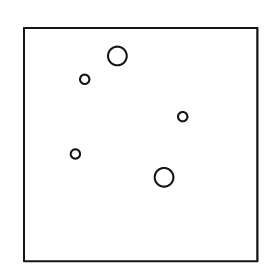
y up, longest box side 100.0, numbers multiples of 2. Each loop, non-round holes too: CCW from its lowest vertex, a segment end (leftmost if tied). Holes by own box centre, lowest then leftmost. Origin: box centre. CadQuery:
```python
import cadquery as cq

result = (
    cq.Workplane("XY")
    .moveTo(-50.0, -50.0)
    .lineTo(50.0, -50.0)
    .lineTo(50.0, 50.0)
    .lineTo(-50.0, 50.0)
    .close()
    .moveTo(10.0, -14.0)
    .circle(4.0)
    .moveTo(-28.0, -4.0)
    .circle(2.0)
    .moveTo(18.0, 12.0)
    .circle(2.0)
    .moveTo(-24.0, 28.0)
    .circle(2.0)
    .moveTo(-10.0, 38.0)
    .circle(4.0)
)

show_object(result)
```